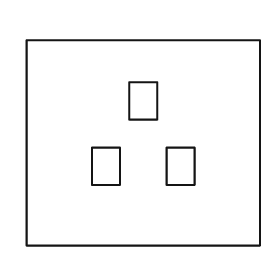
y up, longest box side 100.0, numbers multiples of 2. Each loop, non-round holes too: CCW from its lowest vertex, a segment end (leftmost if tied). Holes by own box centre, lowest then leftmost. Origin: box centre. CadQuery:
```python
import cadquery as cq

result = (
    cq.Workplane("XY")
    .moveTo(-50.0, -44.0)
    .lineTo(50.0, -44.0)
    .lineTo(50.0, 44.0)
    .lineTo(-50.0, 44.0)
    .close()
    .moveTo(-22.0, -18.0)
    .lineTo(-10.0, -18.0)
    .lineTo(-10.0, -2.0)
    .lineTo(-22.0, -2.0)
    .close()
    .moveTo(10.0, -18.0)
    .lineTo(22.0, -18.0)
    .lineTo(22.0, -2.0)
    .lineTo(10.0, -2.0)
    .close()
    .moveTo(-6.0, 10.0)
    .lineTo(6.0, 10.0)
    .lineTo(6.0, 26.0)
    .lineTo(-6.0, 26.0)
    .close()
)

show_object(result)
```